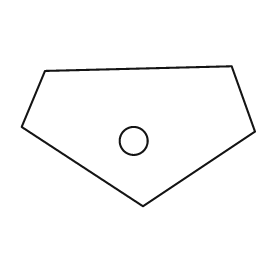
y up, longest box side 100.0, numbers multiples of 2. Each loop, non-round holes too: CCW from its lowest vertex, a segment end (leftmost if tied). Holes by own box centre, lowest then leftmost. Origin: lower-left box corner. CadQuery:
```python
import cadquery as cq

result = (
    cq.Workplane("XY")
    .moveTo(52.0, 0.0)
    .lineTo(100.0, 32.0)
    .lineTo(90.0, 60.0)
    .lineTo(10.0, 58.0)
    .lineTo(0.0, 34.0)
    .close()
    .moveTo(48.0, 28.0)
    .circle(6.0)
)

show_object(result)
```